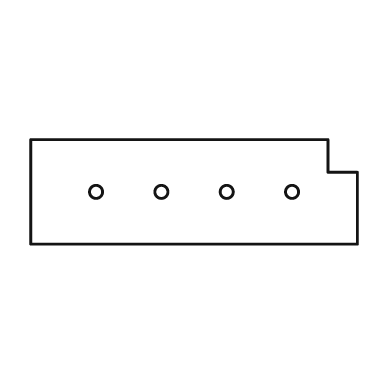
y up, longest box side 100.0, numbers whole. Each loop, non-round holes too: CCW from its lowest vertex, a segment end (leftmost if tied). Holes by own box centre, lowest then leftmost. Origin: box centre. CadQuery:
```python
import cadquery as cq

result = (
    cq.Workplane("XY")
    .moveTo(-50.0, -16.0)
    .lineTo(50.0, -16.0)
    .lineTo(50.0, 6.0)
    .lineTo(41.0, 6.0)
    .lineTo(41.0, 16.0)
    .lineTo(-50.0, 16.0)
    .close()
    .moveTo(-30.0, 0.0)
    .circle(2.0)
    .moveTo(-10.0, 0.0)
    .circle(2.0)
    .moveTo(10.0, 0.0)
    .circle(2.0)
    .moveTo(30.0, 0.0)
    .circle(2.0)
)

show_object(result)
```